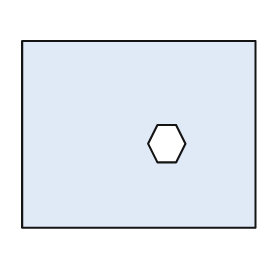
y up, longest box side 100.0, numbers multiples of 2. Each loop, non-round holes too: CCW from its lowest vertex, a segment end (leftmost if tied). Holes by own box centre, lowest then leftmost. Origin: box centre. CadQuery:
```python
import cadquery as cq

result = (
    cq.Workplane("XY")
    .moveTo(-50.0, -40.0)
    .lineTo(50.0, -40.0)
    .lineTo(50.0, 40.0)
    .lineTo(-50.0, 40.0)
    .close()
    .moveTo(8.0, -12.0)
    .lineTo(16.0, -12.0)
    .lineTo(20.0, -4.0)
    .lineTo(16.0, 4.0)
    .lineTo(8.0, 4.0)
    .lineTo(4.0, -4.0)
    .close()
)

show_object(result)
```